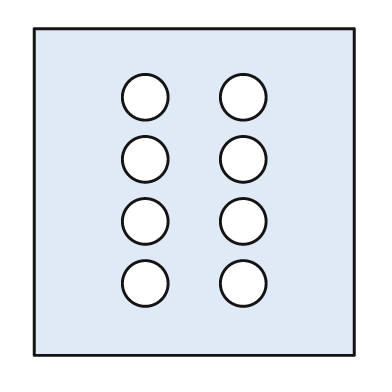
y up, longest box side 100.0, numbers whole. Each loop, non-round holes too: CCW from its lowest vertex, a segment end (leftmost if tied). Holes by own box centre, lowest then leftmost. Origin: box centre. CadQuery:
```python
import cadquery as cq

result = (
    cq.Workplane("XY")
    .moveTo(-49.0, -50.0)
    .lineTo(49.0, -50.0)
    .lineTo(49.0, 50.0)
    .lineTo(-49.0, 50.0)
    .close()
    .moveTo(-15.0, -28.0)
    .circle(7.0)
    .moveTo(15.0, -28.0)
    .circle(7.0)
    .moveTo(-15.0, -9.0)
    .circle(7.0)
    .moveTo(15.0, -9.0)
    .circle(7.0)
    .moveTo(-15.0, 10.0)
    .circle(7.0)
    .moveTo(15.0, 10.0)
    .circle(7.0)
    .moveTo(-15.0, 29.0)
    .circle(7.0)
    .moveTo(15.0, 29.0)
    .circle(7.0)
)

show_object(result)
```